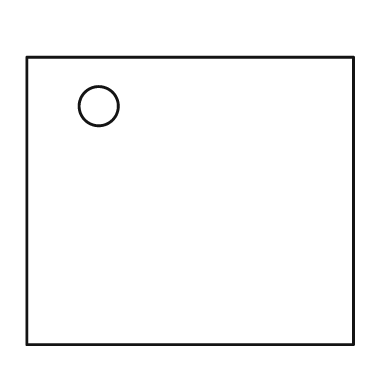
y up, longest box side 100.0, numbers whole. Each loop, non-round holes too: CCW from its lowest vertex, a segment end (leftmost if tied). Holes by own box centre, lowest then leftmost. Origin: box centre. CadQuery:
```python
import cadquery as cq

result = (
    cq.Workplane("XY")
    .moveTo(-50.0, -44.0)
    .lineTo(50.0, -44.0)
    .lineTo(50.0, 44.0)
    .lineTo(-50.0, 44.0)
    .close()
    .moveTo(-28.0, 29.0)
    .circle(6.0)
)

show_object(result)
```